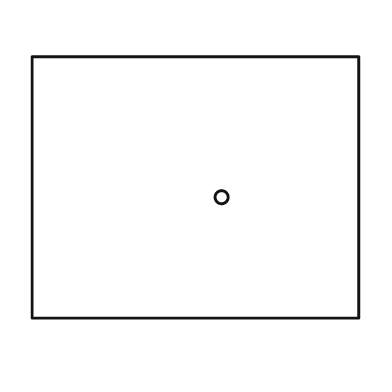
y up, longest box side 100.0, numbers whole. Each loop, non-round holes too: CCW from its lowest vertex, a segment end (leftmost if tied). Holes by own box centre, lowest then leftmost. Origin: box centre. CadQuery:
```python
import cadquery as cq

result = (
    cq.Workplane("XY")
    .moveTo(-50.0, -40.0)
    .lineTo(50.0, -40.0)
    .lineTo(50.0, 40.0)
    .lineTo(-50.0, 40.0)
    .close()
    .moveTo(8.0, -3.0)
    .circle(2.0)
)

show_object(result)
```